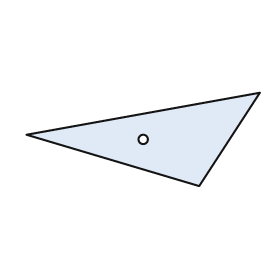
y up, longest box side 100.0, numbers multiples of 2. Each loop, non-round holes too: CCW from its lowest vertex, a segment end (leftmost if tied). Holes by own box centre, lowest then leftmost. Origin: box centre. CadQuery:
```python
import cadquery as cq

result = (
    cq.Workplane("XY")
    .moveTo(24.0, -20.0)
    .lineTo(50.0, 20.0)
    .lineTo(-50.0, 2.0)
    .close()
    .moveTo(0.0, 0.0)
    .circle(2.0)
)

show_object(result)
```